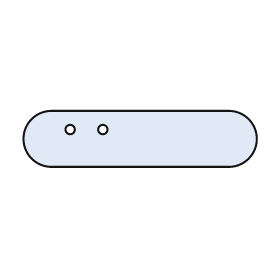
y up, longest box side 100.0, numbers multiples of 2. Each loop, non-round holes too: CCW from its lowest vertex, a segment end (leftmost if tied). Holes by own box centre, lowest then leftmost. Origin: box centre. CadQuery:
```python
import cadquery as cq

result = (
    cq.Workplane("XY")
    .moveTo(-38.0, -12.0)
    .lineTo(38.0, -12.0)
    .threePointArc((50.0, 0.0), (38.0, 12.0))
    .lineTo(-38.0, 12.0)
    .threePointArc((-50.0, 0.0), (-38.0, -12.0))
    .close()
    .moveTo(-30.0, 4.0)
    .circle(2.0)
    .moveTo(-16.0, 4.0)
    .circle(2.0)
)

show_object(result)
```